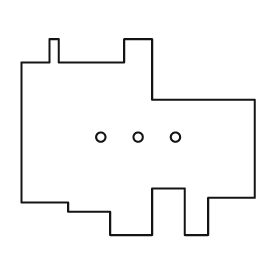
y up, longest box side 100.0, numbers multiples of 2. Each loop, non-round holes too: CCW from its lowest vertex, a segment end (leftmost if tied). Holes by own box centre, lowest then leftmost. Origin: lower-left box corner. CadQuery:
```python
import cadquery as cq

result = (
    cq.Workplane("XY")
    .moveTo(38.0, 0.0)
    .lineTo(56.0, 0.0)
    .lineTo(56.0, 20.0)
    .lineTo(70.0, 20.0)
    .lineTo(70.0, 0.0)
    .lineTo(80.0, 0.0)
    .lineTo(80.0, 16.0)
    .lineTo(100.0, 16.0)
    .lineTo(100.0, 58.0)
    .lineTo(56.0, 58.0)
    .lineTo(56.0, 84.0)
    .lineTo(44.0, 84.0)
    .lineTo(44.0, 74.0)
    .lineTo(16.0, 74.0)
    .lineTo(16.0, 84.0)
    .lineTo(12.0, 84.0)
    .lineTo(12.0, 74.0)
    .lineTo(0.0, 74.0)
    .lineTo(0.0, 14.0)
    .lineTo(20.0, 14.0)
    .lineTo(20.0, 10.0)
    .lineTo(38.0, 10.0)
    .close()
    .moveTo(34.0, 42.0)
    .circle(2.0)
    .moveTo(50.0, 42.0)
    .circle(2.0)
    .moveTo(66.0, 42.0)
    .circle(2.0)
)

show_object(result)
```